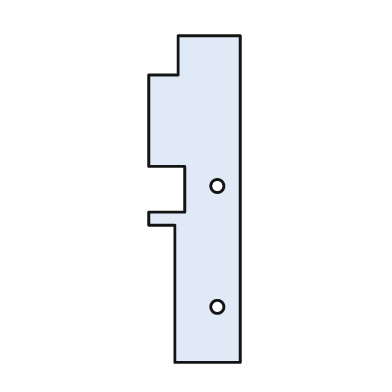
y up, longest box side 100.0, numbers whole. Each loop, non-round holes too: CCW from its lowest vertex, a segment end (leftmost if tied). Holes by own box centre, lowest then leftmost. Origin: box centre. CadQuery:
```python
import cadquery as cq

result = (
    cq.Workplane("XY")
    .moveTo(-6.0, -50.0)
    .lineTo(14.0, -50.0)
    .lineTo(14.0, 50.0)
    .lineTo(-5.0, 50.0)
    .lineTo(-5.0, 38.0)
    .lineTo(-14.0, 38.0)
    .lineTo(-14.0, 10.0)
    .lineTo(-3.0, 10.0)
    .lineTo(-3.0, -4.0)
    .lineTo(-14.0, -4.0)
    .lineTo(-14.0, -8.0)
    .lineTo(-6.0, -8.0)
    .close()
    .moveTo(7.0, -33.0)
    .circle(2.0)
    .moveTo(7.0, 4.0)
    .circle(2.0)
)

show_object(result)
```